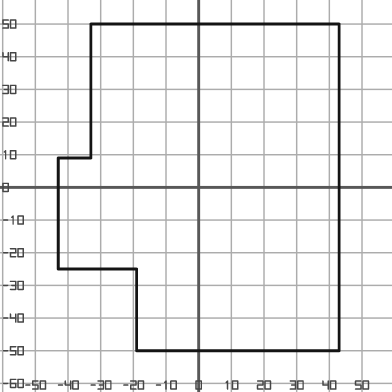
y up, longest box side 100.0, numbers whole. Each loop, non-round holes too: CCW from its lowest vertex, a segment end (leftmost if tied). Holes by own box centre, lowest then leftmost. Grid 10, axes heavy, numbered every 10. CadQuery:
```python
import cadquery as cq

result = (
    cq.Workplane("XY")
    .moveTo(-19.0, -50.0)
    .lineTo(43.0, -50.0)
    .lineTo(43.0, 50.0)
    .lineTo(-33.0, 50.0)
    .lineTo(-33.0, 9.0)
    .lineTo(-43.0, 9.0)
    .lineTo(-43.0, -25.0)
    .lineTo(-19.0, -25.0)
    .close()
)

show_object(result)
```